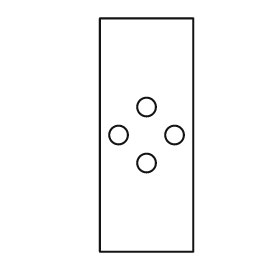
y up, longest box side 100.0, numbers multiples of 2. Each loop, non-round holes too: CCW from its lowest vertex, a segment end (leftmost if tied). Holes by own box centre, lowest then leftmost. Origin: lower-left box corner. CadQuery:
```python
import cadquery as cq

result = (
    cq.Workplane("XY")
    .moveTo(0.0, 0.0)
    .lineTo(40.0, 0.0)
    .lineTo(40.0, 100.0)
    .lineTo(0.0, 100.0)
    .close()
    .moveTo(20.0, 38.0)
    .circle(4.0)
    .moveTo(8.0, 50.0)
    .circle(4.0)
    .moveTo(32.0, 50.0)
    .circle(4.0)
    .moveTo(20.0, 62.0)
    .circle(4.0)
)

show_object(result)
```